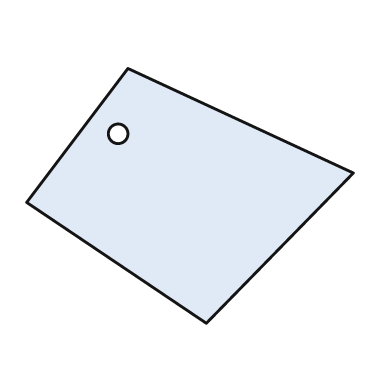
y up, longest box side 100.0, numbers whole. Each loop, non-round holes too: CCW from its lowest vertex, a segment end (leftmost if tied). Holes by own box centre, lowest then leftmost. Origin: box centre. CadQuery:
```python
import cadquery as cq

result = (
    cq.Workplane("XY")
    .moveTo(5.0, -39.0)
    .lineTo(50.0, 7.0)
    .lineTo(-19.0, 39.0)
    .lineTo(-50.0, -2.0)
    .close()
    .moveTo(-22.0, 19.0)
    .circle(3.0)
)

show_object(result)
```